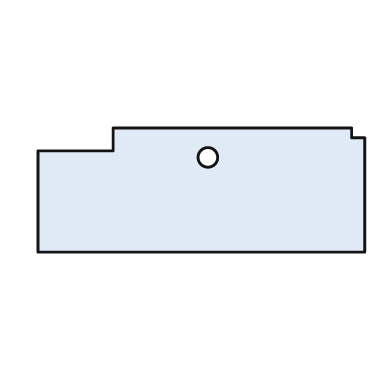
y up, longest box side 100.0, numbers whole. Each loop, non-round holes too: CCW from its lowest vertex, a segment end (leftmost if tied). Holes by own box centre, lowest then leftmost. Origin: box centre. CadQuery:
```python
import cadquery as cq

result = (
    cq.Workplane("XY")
    .moveTo(-50.0, -19.0)
    .lineTo(50.0, -19.0)
    .lineTo(50.0, 16.0)
    .lineTo(46.0, 16.0)
    .lineTo(46.0, 19.0)
    .lineTo(-27.0, 19.0)
    .lineTo(-27.0, 12.0)
    .lineTo(-50.0, 12.0)
    .close()
    .moveTo(2.0, 10.0)
    .circle(3.0)
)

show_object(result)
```